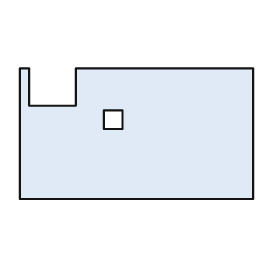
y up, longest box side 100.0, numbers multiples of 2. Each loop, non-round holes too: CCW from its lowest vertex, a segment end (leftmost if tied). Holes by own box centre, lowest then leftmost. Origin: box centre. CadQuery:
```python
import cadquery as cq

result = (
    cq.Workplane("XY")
    .moveTo(-50.0, -28.0)
    .lineTo(50.0, -28.0)
    .lineTo(50.0, 28.0)
    .lineTo(-26.0, 28.0)
    .lineTo(-26.0, 12.0)
    .lineTo(-46.0, 12.0)
    .lineTo(-46.0, 28.0)
    .lineTo(-50.0, 28.0)
    .close()
    .moveTo(-14.0, 2.0)
    .lineTo(-6.0, 2.0)
    .lineTo(-6.0, 10.0)
    .lineTo(-14.0, 10.0)
    .close()
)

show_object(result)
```